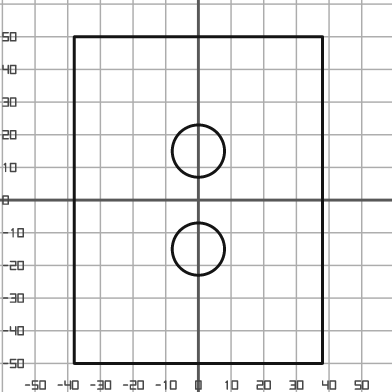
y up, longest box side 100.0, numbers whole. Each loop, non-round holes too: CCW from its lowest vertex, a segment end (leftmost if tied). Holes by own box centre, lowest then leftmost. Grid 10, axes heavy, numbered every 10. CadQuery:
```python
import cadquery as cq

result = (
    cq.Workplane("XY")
    .moveTo(-38.0, -50.0)
    .lineTo(38.0, -50.0)
    .lineTo(38.0, 50.0)
    .lineTo(-38.0, 50.0)
    .close()
    .moveTo(0.0, -15.0)
    .circle(8.0)
    .moveTo(0.0, 15.0)
    .circle(8.0)
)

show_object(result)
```